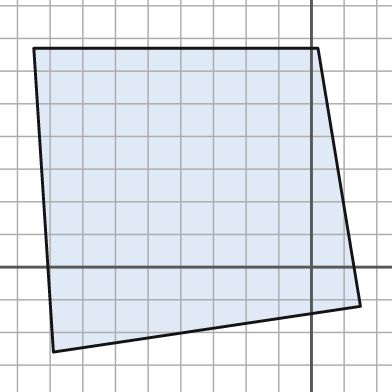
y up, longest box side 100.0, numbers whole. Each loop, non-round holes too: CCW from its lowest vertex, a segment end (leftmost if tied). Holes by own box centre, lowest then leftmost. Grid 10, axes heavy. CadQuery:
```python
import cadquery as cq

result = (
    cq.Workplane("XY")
    .moveTo(-79.0, -26.0)
    .lineTo(15.0, -12.0)
    .lineTo(2.0, 67.0)
    .lineTo(-85.0, 67.0)
    .close()
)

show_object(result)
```